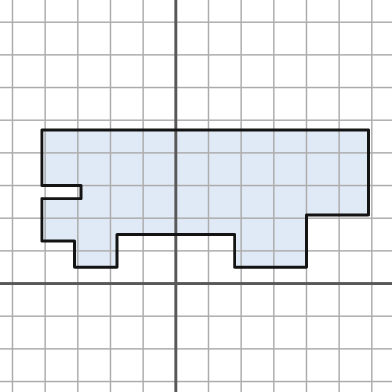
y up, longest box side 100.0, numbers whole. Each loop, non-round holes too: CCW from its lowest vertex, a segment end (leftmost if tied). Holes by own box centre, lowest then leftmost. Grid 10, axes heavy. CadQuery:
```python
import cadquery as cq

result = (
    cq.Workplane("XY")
    .moveTo(-31.0, 5.0)
    .lineTo(-18.0, 5.0)
    .lineTo(-18.0, 15.0)
    .lineTo(18.0, 15.0)
    .lineTo(18.0, 5.0)
    .lineTo(40.0, 5.0)
    .lineTo(40.0, 21.0)
    .lineTo(59.0, 21.0)
    .lineTo(59.0, 47.0)
    .lineTo(-41.0, 47.0)
    .lineTo(-41.0, 30.0)
    .lineTo(-29.0, 30.0)
    .lineTo(-29.0, 26.0)
    .lineTo(-41.0, 26.0)
    .lineTo(-41.0, 13.0)
    .lineTo(-31.0, 13.0)
    .close()
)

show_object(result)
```